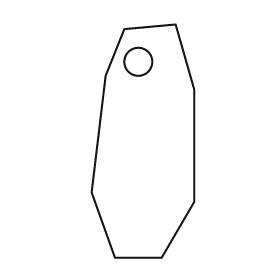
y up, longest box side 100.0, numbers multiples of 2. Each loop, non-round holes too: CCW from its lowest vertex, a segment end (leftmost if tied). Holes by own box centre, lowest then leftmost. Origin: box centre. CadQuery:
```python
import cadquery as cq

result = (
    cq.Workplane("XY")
    .moveTo(-12.0, -50.0)
    .lineTo(8.0, -50.0)
    .lineTo(22.0, -26.0)
    .lineTo(22.0, 22.0)
    .lineTo(14.0, 50.0)
    .lineTo(-8.0, 48.0)
    .lineTo(-16.0, 28.0)
    .lineTo(-22.0, -22.0)
    .close()
    .moveTo(-2.0, 34.0)
    .circle(6.0)
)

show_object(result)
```